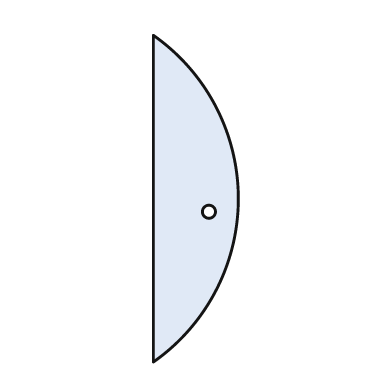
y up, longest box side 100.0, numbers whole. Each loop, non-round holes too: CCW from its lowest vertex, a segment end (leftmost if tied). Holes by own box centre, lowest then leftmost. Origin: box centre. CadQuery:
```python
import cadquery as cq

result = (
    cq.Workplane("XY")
    .moveTo(-13.0, -50.0)
    .threePointArc((13.0, 0.0), (-13.0, 50.0))
    .close()
    .moveTo(4.0, -4.0)
    .circle(2.0)
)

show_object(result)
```